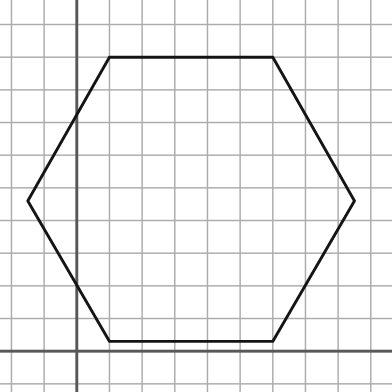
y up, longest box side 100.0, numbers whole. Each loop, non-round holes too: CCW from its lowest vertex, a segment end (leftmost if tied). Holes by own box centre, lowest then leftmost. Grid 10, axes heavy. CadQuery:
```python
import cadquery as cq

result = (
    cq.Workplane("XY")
    .moveTo(10.0, 3.0)
    .lineTo(60.0, 3.0)
    .lineTo(85.0, 46.0)
    .lineTo(60.0, 90.0)
    .lineTo(10.0, 90.0)
    .lineTo(-15.0, 46.0)
    .close()
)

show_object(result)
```